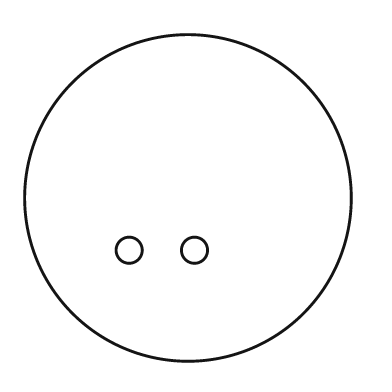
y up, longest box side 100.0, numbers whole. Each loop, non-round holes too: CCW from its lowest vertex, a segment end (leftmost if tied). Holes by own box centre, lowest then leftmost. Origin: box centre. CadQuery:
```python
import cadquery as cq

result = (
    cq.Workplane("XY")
    .moveTo(0.0, 0.0)
    .circle(50.0)
    .moveTo(-18.0, -16.0)
    .circle(4.0)
    .moveTo(2.0, -16.0)
    .circle(4.0)
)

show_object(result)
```